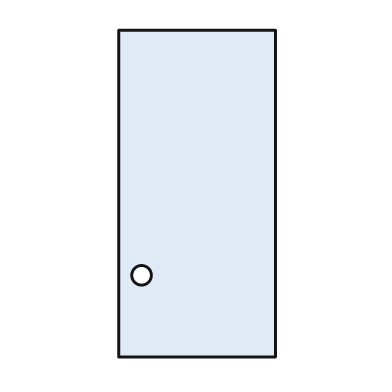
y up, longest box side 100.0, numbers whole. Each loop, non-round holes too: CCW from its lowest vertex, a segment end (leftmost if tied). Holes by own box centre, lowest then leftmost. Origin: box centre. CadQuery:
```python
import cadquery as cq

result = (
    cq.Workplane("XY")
    .moveTo(-24.0, -50.0)
    .lineTo(24.0, -50.0)
    .lineTo(24.0, 50.0)
    .lineTo(-24.0, 50.0)
    .close()
    .moveTo(-17.0, -25.0)
    .circle(3.0)
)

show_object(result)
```